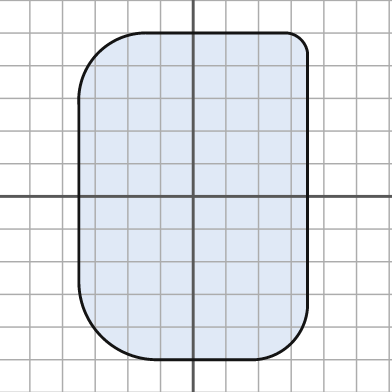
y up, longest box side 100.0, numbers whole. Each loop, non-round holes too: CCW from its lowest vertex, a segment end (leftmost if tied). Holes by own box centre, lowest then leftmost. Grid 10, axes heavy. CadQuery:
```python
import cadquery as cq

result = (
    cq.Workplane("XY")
    .moveTo(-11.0, -50.0)
    .lineTo(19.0, -50.0)
    .threePointArc((30.0, -45.0), (35.0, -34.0))
    .lineTo(35.0, 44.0)
    .threePointArc((33.0, 48.0), (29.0, 50.0))
    .lineTo(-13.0, 50.0)
    .threePointArc((-29.0, 44.0), (-35.0, 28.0))
    .lineTo(-35.0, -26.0)
    .threePointArc((-28.0, -43.0), (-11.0, -50.0))
    .close()
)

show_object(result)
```